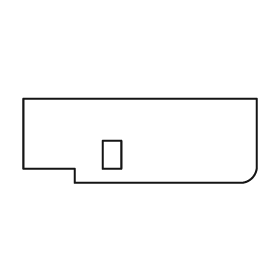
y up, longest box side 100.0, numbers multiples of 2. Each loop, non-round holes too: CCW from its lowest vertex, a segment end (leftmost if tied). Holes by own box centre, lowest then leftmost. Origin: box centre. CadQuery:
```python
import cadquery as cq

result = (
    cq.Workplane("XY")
    .moveTo(-28.0, -18.0)
    .lineTo(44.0, -18.0)
    .threePointArc((48.0, -16.0), (50.0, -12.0))
    .lineTo(50.0, 18.0)
    .lineTo(-50.0, 18.0)
    .lineTo(-50.0, -12.0)
    .lineTo(-28.0, -12.0)
    .close()
    .moveTo(-16.0, -12.0)
    .lineTo(-8.0, -12.0)
    .lineTo(-8.0, 0.0)
    .lineTo(-16.0, 0.0)
    .close()
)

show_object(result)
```